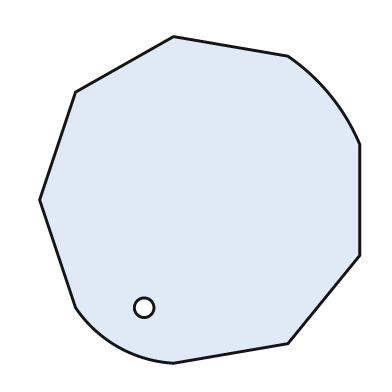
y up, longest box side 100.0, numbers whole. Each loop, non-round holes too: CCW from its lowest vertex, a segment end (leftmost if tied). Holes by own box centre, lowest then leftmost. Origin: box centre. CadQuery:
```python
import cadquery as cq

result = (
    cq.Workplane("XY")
    .moveTo(-8.0, -50.0)
    .lineTo(27.0, -44.0)
    .lineTo(49.0, -17.0)
    .lineTo(49.0, 17.0)
    .threePointArc((40.0, 32.0), (27.0, 44.0))
    .lineTo(-8.0, 50.0)
    .lineTo(-38.0, 33.0)
    .lineTo(-49.0, 0.0)
    .lineTo(-38.0, -33.0)
    .threePointArc((-25.0, -45.0), (-8.0, -50.0))
    .close()
    .moveTo(-17.0, -33.0)
    .circle(3.0)
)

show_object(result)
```